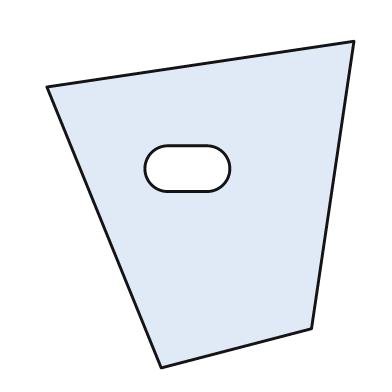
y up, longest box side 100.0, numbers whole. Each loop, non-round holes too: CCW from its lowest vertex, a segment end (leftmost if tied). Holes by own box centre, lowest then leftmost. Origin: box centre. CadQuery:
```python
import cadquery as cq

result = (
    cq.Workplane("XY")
    .moveTo(-12.0, -50.0)
    .lineTo(34.0, -38.0)
    .lineTo(47.0, 50.0)
    .lineTo(-47.0, 36.0)
    .close()
    .moveTo(-10.0, 4.0)
    .lineTo(2.0, 4.0)
    .threePointArc((9.0, 11.0), (2.0, 18.0))
    .lineTo(-10.0, 18.0)
    .threePointArc((-17.0, 11.0), (-10.0, 4.0))
    .close()
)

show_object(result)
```